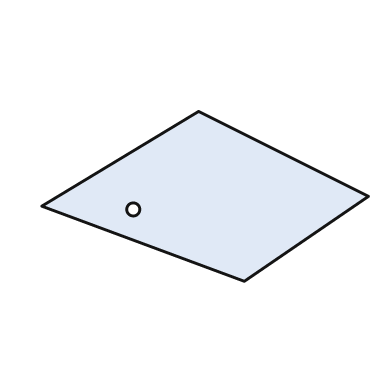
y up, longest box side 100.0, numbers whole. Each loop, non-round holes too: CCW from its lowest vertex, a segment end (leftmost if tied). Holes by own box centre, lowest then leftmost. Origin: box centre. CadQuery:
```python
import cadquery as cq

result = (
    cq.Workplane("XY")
    .moveTo(12.0, -26.0)
    .lineTo(50.0, 0.0)
    .lineTo(-2.0, 26.0)
    .lineTo(-50.0, -3.0)
    .close()
    .moveTo(-22.0, -4.0)
    .circle(2.0)
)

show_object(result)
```